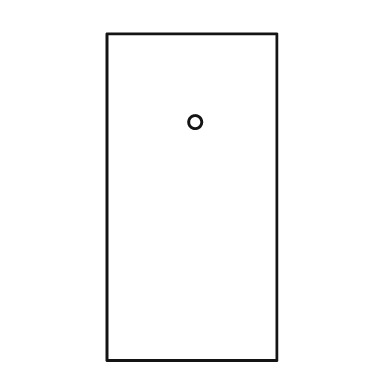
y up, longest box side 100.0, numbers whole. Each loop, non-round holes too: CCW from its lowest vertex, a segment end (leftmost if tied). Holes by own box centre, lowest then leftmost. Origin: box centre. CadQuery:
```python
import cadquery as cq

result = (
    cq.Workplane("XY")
    .moveTo(-26.0, -50.0)
    .lineTo(26.0, -50.0)
    .lineTo(26.0, 50.0)
    .lineTo(-26.0, 50.0)
    .close()
    .moveTo(1.0, 23.0)
    .circle(2.0)
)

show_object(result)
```